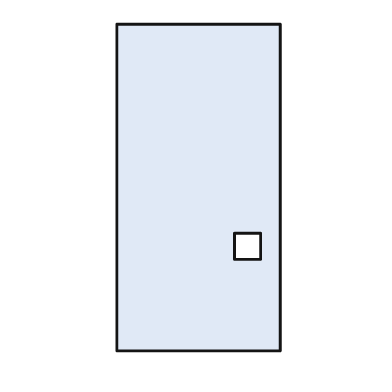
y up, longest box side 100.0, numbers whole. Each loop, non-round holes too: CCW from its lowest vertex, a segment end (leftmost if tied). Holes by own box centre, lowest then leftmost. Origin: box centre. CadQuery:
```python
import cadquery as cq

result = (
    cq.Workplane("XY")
    .moveTo(-25.0, -50.0)
    .lineTo(25.0, -50.0)
    .lineTo(25.0, 50.0)
    .lineTo(-25.0, 50.0)
    .close()
    .moveTo(11.0, -22.0)
    .lineTo(19.0, -22.0)
    .lineTo(19.0, -14.0)
    .lineTo(11.0, -14.0)
    .close()
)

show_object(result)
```